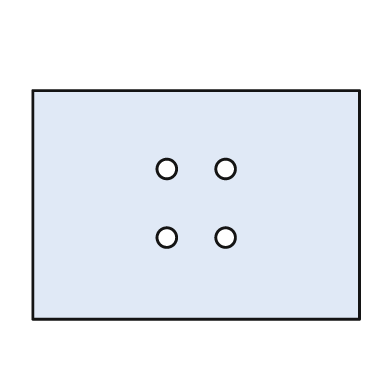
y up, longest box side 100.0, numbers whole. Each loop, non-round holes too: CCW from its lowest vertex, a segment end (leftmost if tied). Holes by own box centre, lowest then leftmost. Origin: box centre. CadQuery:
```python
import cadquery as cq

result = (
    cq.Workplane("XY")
    .moveTo(-50.0, -35.0)
    .lineTo(50.0, -35.0)
    .lineTo(50.0, 35.0)
    .lineTo(-50.0, 35.0)
    .close()
    .moveTo(-9.0, -10.0)
    .circle(3.0)
    .moveTo(9.0, -10.0)
    .circle(3.0)
    .moveTo(-9.0, 11.0)
    .circle(3.0)
    .moveTo(9.0, 11.0)
    .circle(3.0)
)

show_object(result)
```